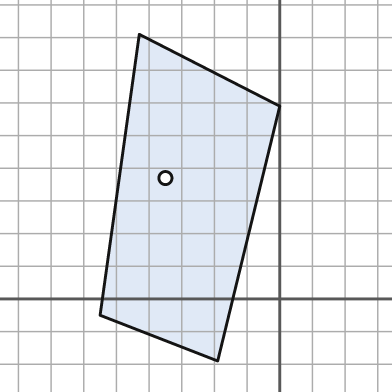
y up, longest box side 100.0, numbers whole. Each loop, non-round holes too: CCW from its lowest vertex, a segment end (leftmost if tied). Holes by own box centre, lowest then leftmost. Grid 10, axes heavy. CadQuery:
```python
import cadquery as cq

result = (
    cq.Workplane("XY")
    .moveTo(-19.0, -19.0)
    .lineTo(0.0, 59.0)
    .lineTo(-43.0, 81.0)
    .lineTo(-55.0, -5.0)
    .close()
    .moveTo(-35.0, 37.0)
    .circle(2.0)
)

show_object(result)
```